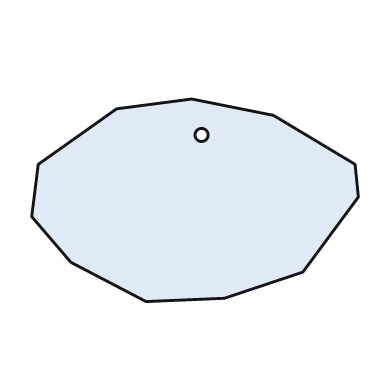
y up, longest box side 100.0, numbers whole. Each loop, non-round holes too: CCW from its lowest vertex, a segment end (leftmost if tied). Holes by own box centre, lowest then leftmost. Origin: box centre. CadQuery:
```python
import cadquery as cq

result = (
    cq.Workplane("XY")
    .moveTo(-15.0, -31.0)
    .lineTo(9.0, -30.0)
    .lineTo(33.0, -22.0)
    .lineTo(50.0, 1.0)
    .lineTo(49.0, 11.0)
    .lineTo(24.0, 26.0)
    .lineTo(-1.0, 31.0)
    .lineTo(-24.0, 28.0)
    .lineTo(-48.0, 11.0)
    .lineTo(-50.0, -5.0)
    .lineTo(-38.0, -19.0)
    .close()
    .moveTo(2.0, 20.0)
    .circle(2.0)
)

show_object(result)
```